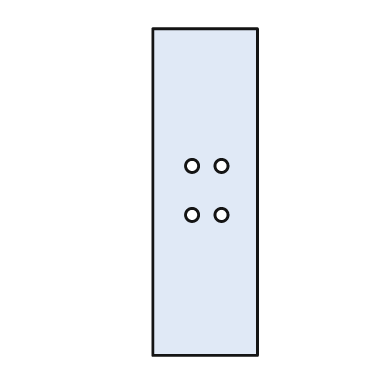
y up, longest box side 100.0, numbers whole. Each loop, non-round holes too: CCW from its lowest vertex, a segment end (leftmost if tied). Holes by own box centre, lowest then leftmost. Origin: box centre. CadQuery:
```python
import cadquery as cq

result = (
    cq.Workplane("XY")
    .moveTo(-16.0, -50.0)
    .lineTo(16.0, -50.0)
    .lineTo(16.0, 50.0)
    .lineTo(-16.0, 50.0)
    .close()
    .moveTo(-4.0, -7.0)
    .circle(2.0)
    .moveTo(5.0, -7.0)
    .circle(2.0)
    .moveTo(-4.0, 8.0)
    .circle(2.0)
    .moveTo(5.0, 8.0)
    .circle(2.0)
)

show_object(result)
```